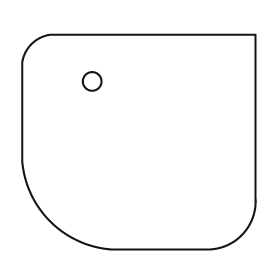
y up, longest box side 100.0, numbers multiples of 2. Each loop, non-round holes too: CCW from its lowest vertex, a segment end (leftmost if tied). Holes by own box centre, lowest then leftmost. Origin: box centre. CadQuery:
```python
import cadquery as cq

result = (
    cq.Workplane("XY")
    .moveTo(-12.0, -46.0)
    .lineTo(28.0, -46.0)
    .threePointArc((44.0, -40.0), (50.0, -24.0))
    .lineTo(50.0, 46.0)
    .lineTo(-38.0, 46.0)
    .threePointArc((-46.0, 42.0), (-50.0, 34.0))
    .lineTo(-50.0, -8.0)
    .threePointArc((-38.0, -34.0), (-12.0, -46.0))
    .close()
    .moveTo(-20.0, 26.0)
    .circle(4.0)
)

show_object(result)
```